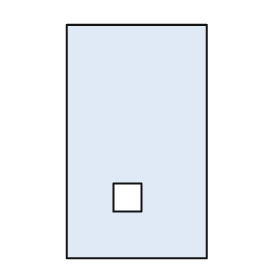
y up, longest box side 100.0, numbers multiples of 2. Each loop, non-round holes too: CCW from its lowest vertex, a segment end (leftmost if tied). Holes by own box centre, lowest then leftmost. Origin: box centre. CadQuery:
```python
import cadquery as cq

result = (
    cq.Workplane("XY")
    .moveTo(-30.0, -50.0)
    .lineTo(30.0, -50.0)
    .lineTo(30.0, 50.0)
    .lineTo(-30.0, 50.0)
    .close()
    .moveTo(-10.0, -30.0)
    .lineTo(2.0, -30.0)
    .lineTo(2.0, -18.0)
    .lineTo(-10.0, -18.0)
    .close()
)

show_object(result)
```